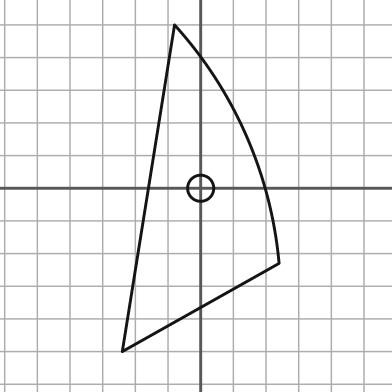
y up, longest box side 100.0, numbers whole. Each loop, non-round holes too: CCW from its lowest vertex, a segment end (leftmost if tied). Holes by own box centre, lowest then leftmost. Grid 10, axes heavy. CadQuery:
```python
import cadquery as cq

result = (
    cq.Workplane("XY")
    .moveTo(-24.0, -50.0)
    .lineTo(24.0, -23.0)
    .threePointArc((14.0, 16.0), (-8.0, 50.0))
    .close()
    .moveTo(0.0, 0.0)
    .circle(4.0)
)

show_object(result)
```